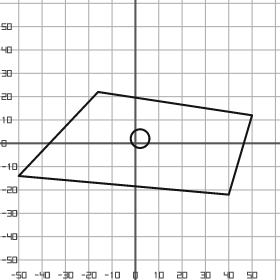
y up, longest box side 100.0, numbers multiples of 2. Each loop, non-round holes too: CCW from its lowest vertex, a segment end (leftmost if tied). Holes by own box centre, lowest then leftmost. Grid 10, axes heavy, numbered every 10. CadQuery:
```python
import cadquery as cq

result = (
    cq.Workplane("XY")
    .moveTo(40.0, -22.0)
    .lineTo(50.0, 12.0)
    .lineTo(-16.0, 22.0)
    .lineTo(-50.0, -14.0)
    .close()
    .moveTo(2.0, 2.0)
    .circle(4.0)
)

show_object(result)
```